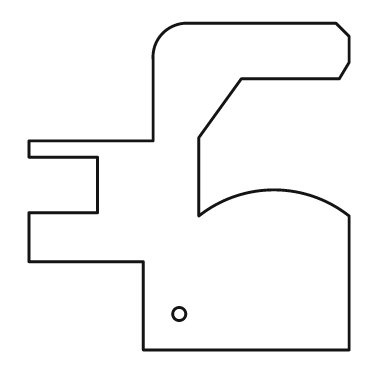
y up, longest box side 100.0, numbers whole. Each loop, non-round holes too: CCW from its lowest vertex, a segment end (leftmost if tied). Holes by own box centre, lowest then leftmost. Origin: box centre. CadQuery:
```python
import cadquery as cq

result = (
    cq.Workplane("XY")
    .moveTo(-14.0, -50.0)
    .lineTo(49.0, -50.0)
    .lineTo(49.0, -9.0)
    .threePointArc((26.0, -1.0), (3.0, -9.0))
    .lineTo(3.0, 15.0)
    .lineTo(16.0, 33.0)
    .lineTo(46.0, 33.0)
    .lineTo(49.0, 38.0)
    .lineTo(49.0, 46.0)
    .lineTo(45.0, 50.0)
    .lineTo(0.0, 50.0)
    .threePointArc((-8.0, 47.0), (-11.0, 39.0))
    .lineTo(-11.0, 14.0)
    .lineTo(-49.0, 14.0)
    .lineTo(-49.0, 9.0)
    .lineTo(-28.0, 9.0)
    .lineTo(-28.0, -8.0)
    .lineTo(-49.0, -8.0)
    .lineTo(-49.0, -23.0)
    .lineTo(-14.0, -23.0)
    .close()
    .moveTo(-3.0, -39.0)
    .circle(2.0)
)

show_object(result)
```